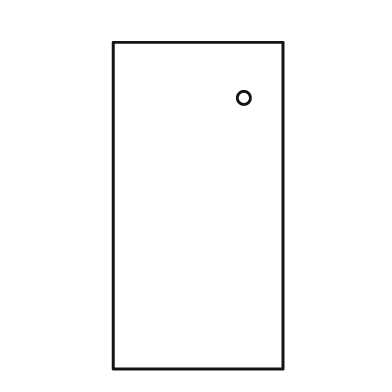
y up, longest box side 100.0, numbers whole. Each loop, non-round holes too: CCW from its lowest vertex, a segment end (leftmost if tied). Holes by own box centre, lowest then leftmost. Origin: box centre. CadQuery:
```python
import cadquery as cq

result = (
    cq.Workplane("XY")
    .moveTo(-26.0, -50.0)
    .lineTo(26.0, -50.0)
    .lineTo(26.0, 50.0)
    .lineTo(-26.0, 50.0)
    .close()
    .moveTo(14.0, 33.0)
    .circle(2.0)
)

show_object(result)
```